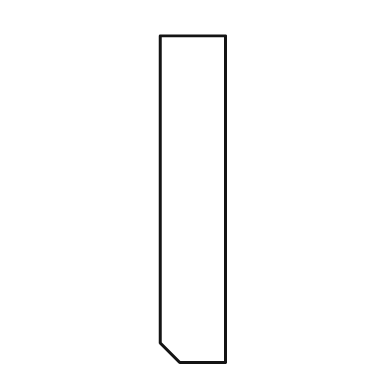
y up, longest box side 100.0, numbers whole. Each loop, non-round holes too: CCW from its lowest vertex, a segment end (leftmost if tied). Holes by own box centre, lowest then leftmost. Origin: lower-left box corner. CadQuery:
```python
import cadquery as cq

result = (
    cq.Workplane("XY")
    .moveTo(6.0, 0.0)
    .lineTo(20.0, 0.0)
    .lineTo(20.0, 100.0)
    .lineTo(0.0, 100.0)
    .lineTo(0.0, 6.0)
    .close()
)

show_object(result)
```